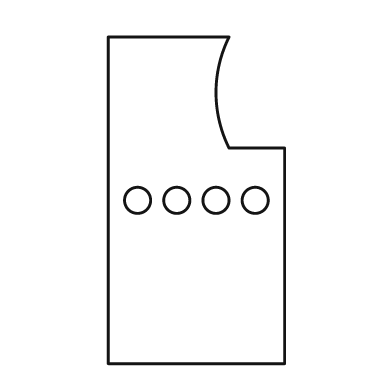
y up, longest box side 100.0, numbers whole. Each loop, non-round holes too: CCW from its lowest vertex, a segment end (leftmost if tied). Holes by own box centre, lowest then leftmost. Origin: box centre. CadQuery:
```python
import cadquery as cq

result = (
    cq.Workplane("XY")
    .moveTo(-27.0, -50.0)
    .lineTo(27.0, -50.0)
    .lineTo(27.0, 16.0)
    .lineTo(10.0, 16.0)
    .threePointArc((6.0, 33.0), (10.0, 50.0))
    .lineTo(-27.0, 50.0)
    .close()
    .moveTo(-18.0, 0.0)
    .circle(4.0)
    .moveTo(-6.0, 0.0)
    .circle(4.0)
    .moveTo(6.0, 0.0)
    .circle(4.0)
    .moveTo(18.0, 0.0)
    .circle(4.0)
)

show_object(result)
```